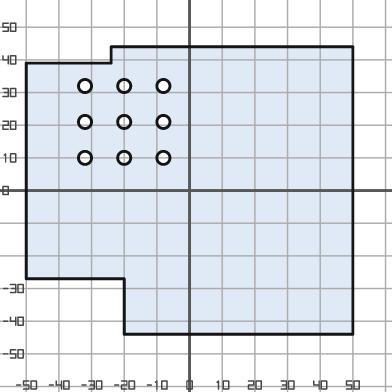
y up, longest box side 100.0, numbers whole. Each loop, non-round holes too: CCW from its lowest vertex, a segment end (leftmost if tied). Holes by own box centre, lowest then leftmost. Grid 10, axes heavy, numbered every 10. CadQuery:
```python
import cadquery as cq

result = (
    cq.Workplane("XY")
    .moveTo(-20.0, -44.0)
    .lineTo(50.0, -44.0)
    .lineTo(50.0, 44.0)
    .lineTo(-24.0, 44.0)
    .lineTo(-24.0, 39.0)
    .lineTo(-50.0, 39.0)
    .lineTo(-50.0, -27.0)
    .lineTo(-20.0, -27.0)
    .close()
    .moveTo(-32.0, 10.0)
    .circle(2.0)
    .moveTo(-20.0, 10.0)
    .circle(2.0)
    .moveTo(-8.0, 10.0)
    .circle(2.0)
    .moveTo(-32.0, 21.0)
    .circle(2.0)
    .moveTo(-20.0, 21.0)
    .circle(2.0)
    .moveTo(-8.0, 21.0)
    .circle(2.0)
    .moveTo(-32.0, 32.0)
    .circle(2.0)
    .moveTo(-20.0, 32.0)
    .circle(2.0)
    .moveTo(-8.0, 32.0)
    .circle(2.0)
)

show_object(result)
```